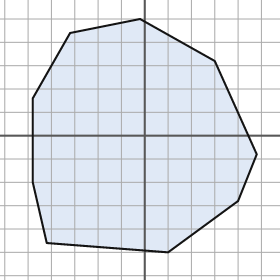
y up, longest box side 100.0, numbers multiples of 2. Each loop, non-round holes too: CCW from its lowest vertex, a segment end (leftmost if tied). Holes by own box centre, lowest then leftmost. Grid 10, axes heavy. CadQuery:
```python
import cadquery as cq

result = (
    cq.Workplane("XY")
    .moveTo(10.0, -50.0)
    .lineTo(40.0, -28.0)
    .lineTo(48.0, -8.0)
    .lineTo(30.0, 32.0)
    .lineTo(-2.0, 50.0)
    .lineTo(-32.0, 44.0)
    .lineTo(-48.0, 16.0)
    .lineTo(-48.0, -20.0)
    .lineTo(-42.0, -46.0)
    .close()
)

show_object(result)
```